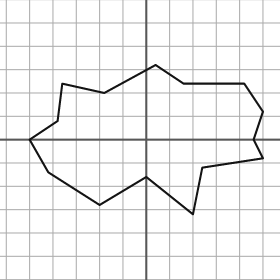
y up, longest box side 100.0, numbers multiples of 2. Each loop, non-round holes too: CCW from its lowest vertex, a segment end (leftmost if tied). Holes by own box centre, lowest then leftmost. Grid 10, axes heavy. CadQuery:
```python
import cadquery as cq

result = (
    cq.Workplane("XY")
    .moveTo(20.0, -32.0)
    .lineTo(24.0, -12.0)
    .lineTo(50.0, -8.0)
    .lineTo(46.0, 0.0)
    .lineTo(50.0, 12.0)
    .lineTo(42.0, 24.0)
    .lineTo(16.0, 24.0)
    .lineTo(4.0, 32.0)
    .lineTo(-18.0, 20.0)
    .lineTo(-36.0, 24.0)
    .lineTo(-38.0, 8.0)
    .lineTo(-50.0, 0.0)
    .lineTo(-42.0, -14.0)
    .lineTo(-20.0, -28.0)
    .lineTo(0.0, -16.0)
    .close()
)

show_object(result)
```